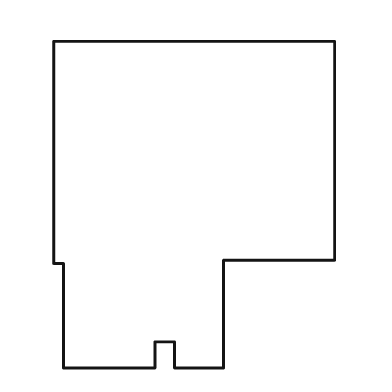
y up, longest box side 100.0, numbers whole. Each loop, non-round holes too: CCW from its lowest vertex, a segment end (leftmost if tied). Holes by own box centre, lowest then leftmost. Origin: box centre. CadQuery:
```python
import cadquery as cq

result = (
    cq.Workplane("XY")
    .moveTo(-40.0, -50.0)
    .lineTo(-12.0, -50.0)
    .lineTo(-12.0, -42.0)
    .lineTo(-6.0, -42.0)
    .lineTo(-6.0, -50.0)
    .lineTo(9.0, -50.0)
    .lineTo(9.0, -17.0)
    .lineTo(43.0, -17.0)
    .lineTo(43.0, 50.0)
    .lineTo(-43.0, 50.0)
    .lineTo(-43.0, -18.0)
    .lineTo(-40.0, -18.0)
    .close()
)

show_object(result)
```